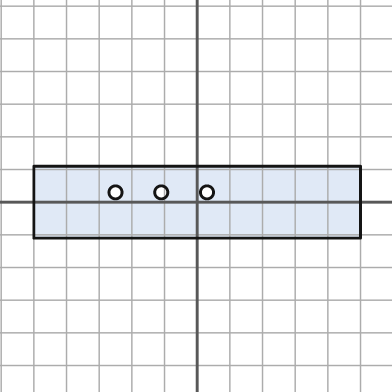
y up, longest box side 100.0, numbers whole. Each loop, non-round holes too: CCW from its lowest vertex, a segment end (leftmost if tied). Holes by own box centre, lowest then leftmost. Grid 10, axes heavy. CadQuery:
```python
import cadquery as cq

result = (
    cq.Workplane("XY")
    .moveTo(-50.0, -11.0)
    .lineTo(50.0, -11.0)
    .lineTo(50.0, 11.0)
    .lineTo(-50.0, 11.0)
    .close()
    .moveTo(-25.0, 3.0)
    .circle(2.0)
    .moveTo(-11.0, 3.0)
    .circle(2.0)
    .moveTo(3.0, 3.0)
    .circle(2.0)
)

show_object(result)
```